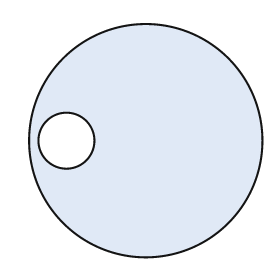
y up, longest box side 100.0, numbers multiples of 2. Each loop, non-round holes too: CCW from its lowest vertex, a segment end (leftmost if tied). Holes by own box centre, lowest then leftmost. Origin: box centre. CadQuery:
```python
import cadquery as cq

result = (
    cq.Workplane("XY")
    .moveTo(0.0, 0.0)
    .circle(50.0)
    .moveTo(-34.0, 0.0)
    .circle(12.0)
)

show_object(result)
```